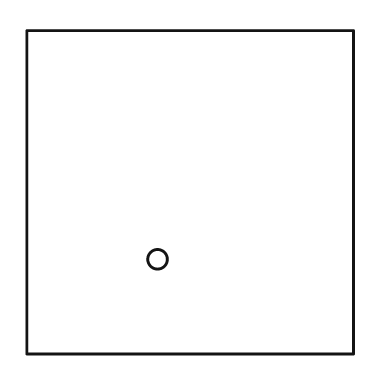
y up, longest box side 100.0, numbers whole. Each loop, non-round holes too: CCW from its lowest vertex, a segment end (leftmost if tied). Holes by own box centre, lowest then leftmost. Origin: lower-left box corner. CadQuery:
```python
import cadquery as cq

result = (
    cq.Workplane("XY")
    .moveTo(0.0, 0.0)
    .lineTo(100.0, 0.0)
    .lineTo(100.0, 99.0)
    .lineTo(0.0, 99.0)
    .close()
    .moveTo(40.0, 29.0)
    .circle(3.0)
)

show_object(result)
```